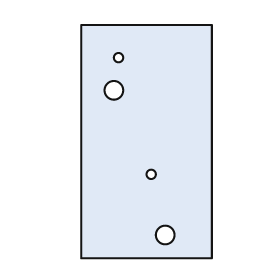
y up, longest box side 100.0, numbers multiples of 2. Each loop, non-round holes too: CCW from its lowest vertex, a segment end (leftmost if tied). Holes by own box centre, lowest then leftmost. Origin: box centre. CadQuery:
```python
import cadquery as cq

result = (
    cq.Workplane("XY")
    .moveTo(-28.0, -50.0)
    .lineTo(28.0, -50.0)
    .lineTo(28.0, 50.0)
    .lineTo(-28.0, 50.0)
    .close()
    .moveTo(8.0, -40.0)
    .circle(4.0)
    .moveTo(2.0, -14.0)
    .circle(2.0)
    .moveTo(-14.0, 22.0)
    .circle(4.0)
    .moveTo(-12.0, 36.0)
    .circle(2.0)
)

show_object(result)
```